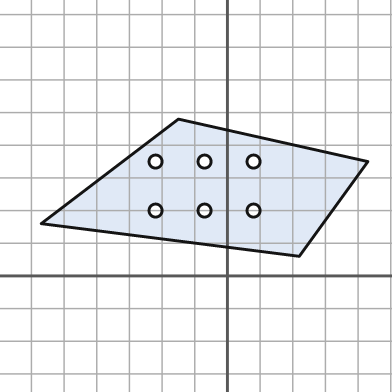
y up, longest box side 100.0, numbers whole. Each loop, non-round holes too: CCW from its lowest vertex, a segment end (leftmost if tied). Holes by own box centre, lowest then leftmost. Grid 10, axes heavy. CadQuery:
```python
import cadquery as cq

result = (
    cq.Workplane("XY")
    .moveTo(22.0, 6.0)
    .lineTo(43.0, 35.0)
    .lineTo(-15.0, 48.0)
    .lineTo(-57.0, 16.0)
    .close()
    .moveTo(-22.0, 20.0)
    .circle(2.0)
    .moveTo(-7.0, 20.0)
    .circle(2.0)
    .moveTo(8.0, 20.0)
    .circle(2.0)
    .moveTo(-22.0, 35.0)
    .circle(2.0)
    .moveTo(-7.0, 35.0)
    .circle(2.0)
    .moveTo(8.0, 35.0)
    .circle(2.0)
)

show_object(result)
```